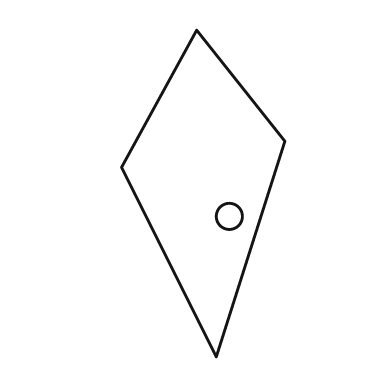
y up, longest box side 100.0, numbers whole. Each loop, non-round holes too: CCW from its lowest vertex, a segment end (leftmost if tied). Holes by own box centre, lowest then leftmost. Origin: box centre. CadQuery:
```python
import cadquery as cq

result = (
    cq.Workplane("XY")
    .moveTo(4.0, -50.0)
    .lineTo(25.0, 16.0)
    .lineTo(-2.0, 50.0)
    .lineTo(-25.0, 8.0)
    .close()
    .moveTo(8.0, -7.0)
    .circle(4.0)
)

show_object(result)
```